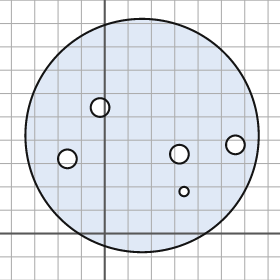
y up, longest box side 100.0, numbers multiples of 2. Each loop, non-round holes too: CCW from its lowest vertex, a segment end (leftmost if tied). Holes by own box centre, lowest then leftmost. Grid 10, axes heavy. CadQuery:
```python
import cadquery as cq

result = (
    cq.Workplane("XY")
    .moveTo(16.0, 42.0)
    .circle(50.0)
    .moveTo(34.0, 18.0)
    .circle(2.0)
    .moveTo(-16.0, 32.0)
    .circle(4.0)
    .moveTo(32.0, 34.0)
    .circle(4.0)
    .moveTo(56.0, 38.0)
    .circle(4.0)
    .moveTo(-2.0, 54.0)
    .circle(4.0)
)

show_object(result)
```